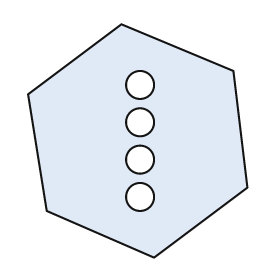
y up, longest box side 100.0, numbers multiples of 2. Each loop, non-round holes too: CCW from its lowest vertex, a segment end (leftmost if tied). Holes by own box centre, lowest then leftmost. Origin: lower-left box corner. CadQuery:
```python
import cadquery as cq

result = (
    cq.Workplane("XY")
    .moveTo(54.0, 0.0)
    .lineTo(94.0, 30.0)
    .lineTo(88.0, 80.0)
    .lineTo(40.0, 100.0)
    .lineTo(0.0, 70.0)
    .lineTo(8.0, 20.0)
    .close()
    .moveTo(48.0, 26.0)
    .circle(6.0)
    .moveTo(48.0, 42.0)
    .circle(6.0)
    .moveTo(48.0, 58.0)
    .circle(6.0)
    .moveTo(48.0, 74.0)
    .circle(6.0)
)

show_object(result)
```